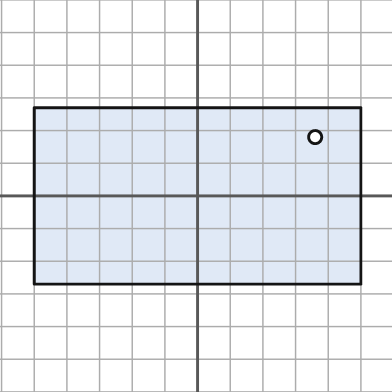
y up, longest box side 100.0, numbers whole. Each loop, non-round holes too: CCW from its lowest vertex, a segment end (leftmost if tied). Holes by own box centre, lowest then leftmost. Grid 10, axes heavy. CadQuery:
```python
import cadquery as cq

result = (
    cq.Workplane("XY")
    .moveTo(-50.0, -27.0)
    .lineTo(50.0, -27.0)
    .lineTo(50.0, 27.0)
    .lineTo(-50.0, 27.0)
    .close()
    .moveTo(36.0, 18.0)
    .circle(2.0)
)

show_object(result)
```